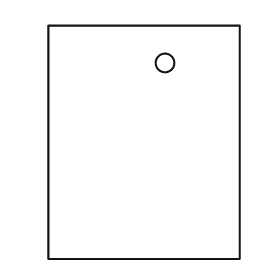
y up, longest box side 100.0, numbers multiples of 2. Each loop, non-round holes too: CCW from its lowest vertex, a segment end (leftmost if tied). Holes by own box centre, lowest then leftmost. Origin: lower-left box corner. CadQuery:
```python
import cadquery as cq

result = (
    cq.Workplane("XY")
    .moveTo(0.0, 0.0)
    .lineTo(82.0, 0.0)
    .lineTo(82.0, 100.0)
    .lineTo(0.0, 100.0)
    .close()
    .moveTo(50.0, 84.0)
    .circle(4.0)
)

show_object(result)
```